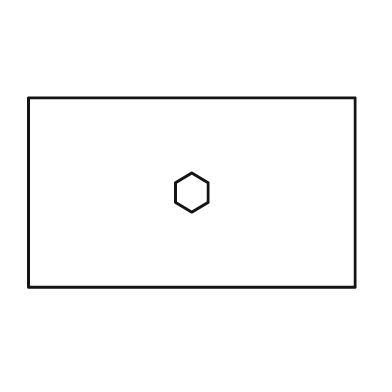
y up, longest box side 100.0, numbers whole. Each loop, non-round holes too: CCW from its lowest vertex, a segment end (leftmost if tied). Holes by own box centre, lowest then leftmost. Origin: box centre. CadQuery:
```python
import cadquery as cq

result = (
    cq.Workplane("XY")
    .moveTo(-50.0, -29.0)
    .lineTo(50.0, -29.0)
    .lineTo(50.0, 29.0)
    .lineTo(-50.0, 29.0)
    .close()
    .moveTo(0.0, -6.0)
    .lineTo(5.0, -3.0)
    .lineTo(5.0, 3.0)
    .lineTo(0.0, 6.0)
    .lineTo(-5.0, 3.0)
    .lineTo(-5.0, -3.0)
    .close()
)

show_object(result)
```